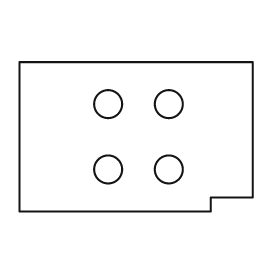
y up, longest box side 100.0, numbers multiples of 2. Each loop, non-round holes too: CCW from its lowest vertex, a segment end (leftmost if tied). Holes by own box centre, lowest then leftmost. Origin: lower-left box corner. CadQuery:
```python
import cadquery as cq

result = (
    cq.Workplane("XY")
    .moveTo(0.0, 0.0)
    .lineTo(82.0, 0.0)
    .lineTo(82.0, 6.0)
    .lineTo(100.0, 6.0)
    .lineTo(100.0, 64.0)
    .lineTo(0.0, 64.0)
    .close()
    .moveTo(38.0, 18.0)
    .circle(6.0)
    .moveTo(64.0, 18.0)
    .circle(6.0)
    .moveTo(38.0, 46.0)
    .circle(6.0)
    .moveTo(64.0, 46.0)
    .circle(6.0)
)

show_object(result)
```